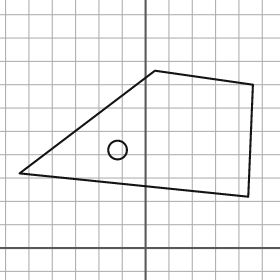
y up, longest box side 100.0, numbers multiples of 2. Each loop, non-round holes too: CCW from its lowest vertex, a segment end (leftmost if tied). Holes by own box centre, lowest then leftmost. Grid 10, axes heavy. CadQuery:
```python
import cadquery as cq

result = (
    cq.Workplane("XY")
    .moveTo(44.0, 22.0)
    .lineTo(46.0, 70.0)
    .lineTo(4.0, 76.0)
    .lineTo(-54.0, 32.0)
    .close()
    .moveTo(-12.0, 42.0)
    .circle(4.0)
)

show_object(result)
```